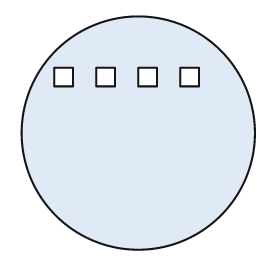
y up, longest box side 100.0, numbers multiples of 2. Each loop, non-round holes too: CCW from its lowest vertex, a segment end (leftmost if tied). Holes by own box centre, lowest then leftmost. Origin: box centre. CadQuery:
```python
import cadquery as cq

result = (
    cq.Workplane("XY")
    .moveTo(0.0, 0.0)
    .circle(50.0)
    .moveTo(-36.0, 20.0)
    .lineTo(-28.0, 20.0)
    .lineTo(-28.0, 28.0)
    .lineTo(-36.0, 28.0)
    .close()
    .moveTo(-18.0, 20.0)
    .lineTo(-10.0, 20.0)
    .lineTo(-10.0, 28.0)
    .lineTo(-18.0, 28.0)
    .close()
    .moveTo(0.0, 20.0)
    .lineTo(8.0, 20.0)
    .lineTo(8.0, 28.0)
    .lineTo(0.0, 28.0)
    .close()
    .moveTo(18.0, 20.0)
    .lineTo(26.0, 20.0)
    .lineTo(26.0, 28.0)
    .lineTo(18.0, 28.0)
    .close()
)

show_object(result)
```